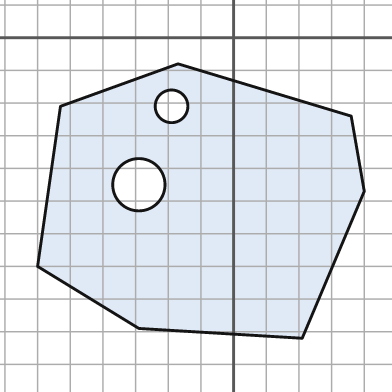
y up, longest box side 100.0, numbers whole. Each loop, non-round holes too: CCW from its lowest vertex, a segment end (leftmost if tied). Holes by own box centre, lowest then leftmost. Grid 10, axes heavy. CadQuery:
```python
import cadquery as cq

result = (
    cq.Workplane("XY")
    .moveTo(21.0, -92.0)
    .lineTo(40.0, -47.0)
    .lineTo(36.0, -24.0)
    .lineTo(-17.0, -8.0)
    .lineTo(-53.0, -21.0)
    .lineTo(-60.0, -70.0)
    .lineTo(-29.0, -89.0)
    .close()
    .moveTo(-29.0, -45.0)
    .circle(8.0)
    .moveTo(-19.0, -21.0)
    .circle(5.0)
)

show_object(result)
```